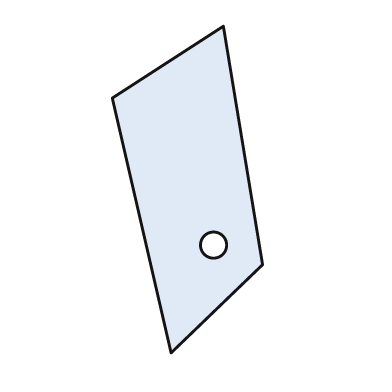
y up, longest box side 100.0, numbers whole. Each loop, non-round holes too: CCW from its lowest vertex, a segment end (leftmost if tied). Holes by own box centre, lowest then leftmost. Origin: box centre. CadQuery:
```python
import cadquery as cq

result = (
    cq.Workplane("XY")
    .moveTo(-5.0, -50.0)
    .lineTo(23.0, -23.0)
    .lineTo(11.0, 50.0)
    .lineTo(-23.0, 28.0)
    .close()
    .moveTo(8.0, -17.0)
    .circle(4.0)
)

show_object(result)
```